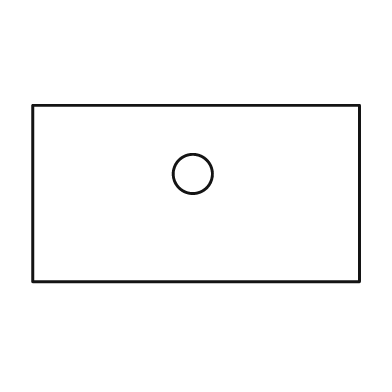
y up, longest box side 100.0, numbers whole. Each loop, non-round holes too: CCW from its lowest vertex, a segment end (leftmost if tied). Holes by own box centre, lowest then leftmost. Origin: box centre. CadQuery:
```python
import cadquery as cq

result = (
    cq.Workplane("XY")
    .moveTo(-50.0, -27.0)
    .lineTo(50.0, -27.0)
    .lineTo(50.0, 27.0)
    .lineTo(-50.0, 27.0)
    .close()
    .moveTo(-1.0, 6.0)
    .circle(6.0)
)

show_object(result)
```